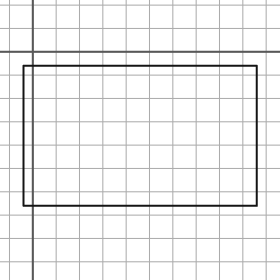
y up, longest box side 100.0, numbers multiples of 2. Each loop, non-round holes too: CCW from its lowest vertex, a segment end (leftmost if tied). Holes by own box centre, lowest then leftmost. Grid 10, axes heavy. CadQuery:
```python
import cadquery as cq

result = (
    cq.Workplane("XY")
    .moveTo(-4.0, -66.0)
    .lineTo(96.0, -66.0)
    .lineTo(96.0, -6.0)
    .lineTo(-4.0, -6.0)
    .close()
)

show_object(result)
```